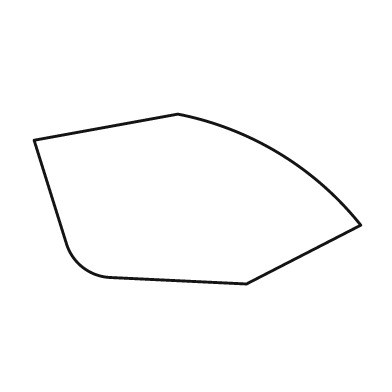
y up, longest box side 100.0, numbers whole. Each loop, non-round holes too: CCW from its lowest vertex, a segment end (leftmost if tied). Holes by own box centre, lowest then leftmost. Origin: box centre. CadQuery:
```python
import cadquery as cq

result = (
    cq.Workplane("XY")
    .moveTo(15.0, -26.0)
    .lineTo(50.0, -8.0)
    .threePointArc((25.0, 14.0), (-6.0, 26.0))
    .lineTo(-50.0, 18.0)
    .lineTo(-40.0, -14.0)
    .threePointArc((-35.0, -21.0), (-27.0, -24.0))
    .close()
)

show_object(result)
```